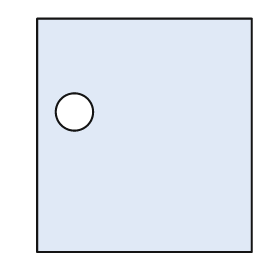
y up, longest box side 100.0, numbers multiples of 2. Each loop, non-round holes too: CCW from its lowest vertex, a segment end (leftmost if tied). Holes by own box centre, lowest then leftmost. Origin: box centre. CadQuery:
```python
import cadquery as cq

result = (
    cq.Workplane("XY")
    .moveTo(-46.0, -50.0)
    .lineTo(46.0, -50.0)
    .lineTo(46.0, 50.0)
    .lineTo(-46.0, 50.0)
    .close()
    .moveTo(-30.0, 10.0)
    .circle(8.0)
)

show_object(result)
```